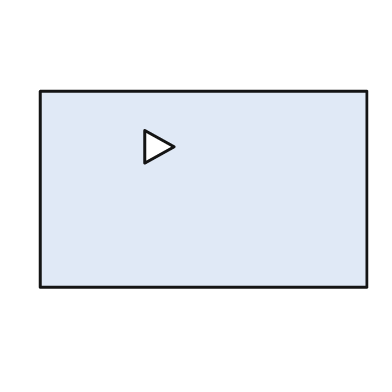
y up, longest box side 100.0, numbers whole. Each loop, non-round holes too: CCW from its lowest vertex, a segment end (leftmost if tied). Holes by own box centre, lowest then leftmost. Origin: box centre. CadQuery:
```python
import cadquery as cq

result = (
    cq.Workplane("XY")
    .moveTo(-50.0, -30.0)
    .lineTo(50.0, -30.0)
    .lineTo(50.0, 30.0)
    .lineTo(-50.0, 30.0)
    .close()
    .moveTo(-18.0, 8.0)
    .lineTo(-9.0, 13.0)
    .lineTo(-18.0, 18.0)
    .close()
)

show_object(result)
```